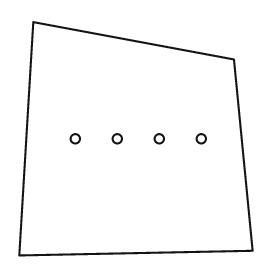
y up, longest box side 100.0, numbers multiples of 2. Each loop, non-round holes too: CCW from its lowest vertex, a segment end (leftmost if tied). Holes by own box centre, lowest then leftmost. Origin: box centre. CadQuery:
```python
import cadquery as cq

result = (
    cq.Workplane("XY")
    .moveTo(-50.0, -50.0)
    .lineTo(50.0, -48.0)
    .lineTo(42.0, 34.0)
    .lineTo(-44.0, 50.0)
    .close()
    .moveTo(-26.0, 0.0)
    .circle(2.0)
    .moveTo(-8.0, 0.0)
    .circle(2.0)
    .moveTo(10.0, 0.0)
    .circle(2.0)
    .moveTo(28.0, 0.0)
    .circle(2.0)
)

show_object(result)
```